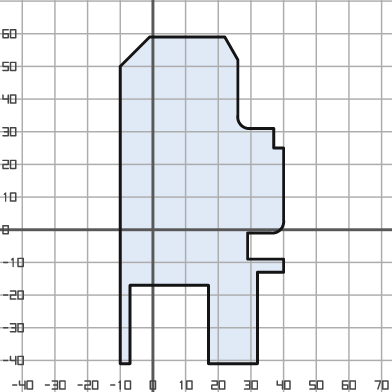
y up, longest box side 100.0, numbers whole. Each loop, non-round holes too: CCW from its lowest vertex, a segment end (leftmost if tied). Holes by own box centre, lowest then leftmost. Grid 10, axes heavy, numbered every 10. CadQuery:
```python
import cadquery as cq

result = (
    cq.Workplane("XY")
    .moveTo(-10.0, -41.0)
    .lineTo(-7.0, -41.0)
    .lineTo(-7.0, -17.0)
    .lineTo(17.0, -17.0)
    .lineTo(17.0, -41.0)
    .lineTo(32.0, -41.0)
    .lineTo(32.0, -13.0)
    .lineTo(40.0, -13.0)
    .lineTo(40.0, -9.0)
    .lineTo(29.0, -9.0)
    .lineTo(29.0, -1.0)
    .lineTo(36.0, -1.0)
    .threePointArc((39.0, 0.0), (40.0, 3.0))
    .lineTo(40.0, 25.0)
    .lineTo(37.0, 25.0)
    .lineTo(37.0, 31.0)
    .lineTo(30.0, 31.0)
    .threePointArc((27.0, 32.0), (26.0, 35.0))
    .lineTo(26.0, 52.0)
    .lineTo(22.0, 59.0)
    .lineTo(-1.0, 59.0)
    .lineTo(-10.0, 50.0)
    .close()
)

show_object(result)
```